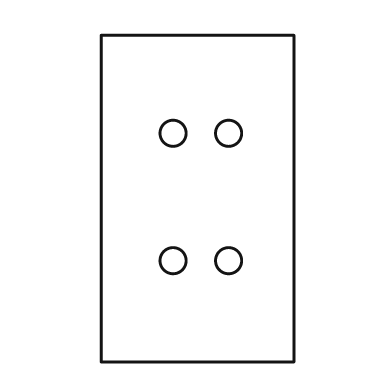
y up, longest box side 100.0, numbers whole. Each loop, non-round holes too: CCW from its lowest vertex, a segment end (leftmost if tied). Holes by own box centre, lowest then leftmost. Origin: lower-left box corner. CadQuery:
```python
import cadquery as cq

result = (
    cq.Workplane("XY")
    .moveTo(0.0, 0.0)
    .lineTo(59.0, 0.0)
    .lineTo(59.0, 100.0)
    .lineTo(0.0, 100.0)
    .close()
    .moveTo(22.0, 31.0)
    .circle(4.0)
    .moveTo(39.0, 31.0)
    .circle(4.0)
    .moveTo(22.0, 70.0)
    .circle(4.0)
    .moveTo(39.0, 70.0)
    .circle(4.0)
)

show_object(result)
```